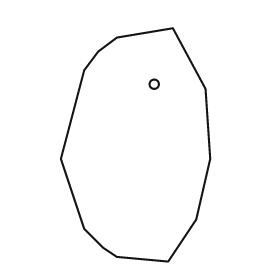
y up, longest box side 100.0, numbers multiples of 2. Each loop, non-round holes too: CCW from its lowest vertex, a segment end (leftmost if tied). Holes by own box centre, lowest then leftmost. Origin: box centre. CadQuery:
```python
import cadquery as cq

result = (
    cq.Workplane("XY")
    .moveTo(14.0, -50.0)
    .lineTo(26.0, -32.0)
    .lineTo(32.0, -6.0)
    .lineTo(30.0, 24.0)
    .lineTo(16.0, 50.0)
    .lineTo(-8.0, 46.0)
    .lineTo(-16.0, 40.0)
    .lineTo(-22.0, 32.0)
    .lineTo(-32.0, -6.0)
    .lineTo(-22.0, -36.0)
    .lineTo(-14.0, -44.0)
    .lineTo(-8.0, -48.0)
    .close()
    .moveTo(8.0, 26.0)
    .circle(2.0)
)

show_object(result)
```